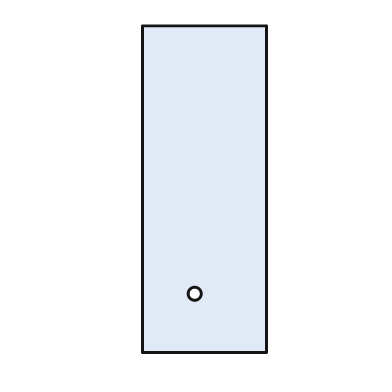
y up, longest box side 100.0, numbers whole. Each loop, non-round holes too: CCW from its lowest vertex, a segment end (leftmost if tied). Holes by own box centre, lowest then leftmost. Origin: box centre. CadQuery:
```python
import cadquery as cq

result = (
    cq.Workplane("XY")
    .moveTo(-19.0, -50.0)
    .lineTo(19.0, -50.0)
    .lineTo(19.0, 50.0)
    .lineTo(-19.0, 50.0)
    .close()
    .moveTo(-3.0, -32.0)
    .circle(2.0)
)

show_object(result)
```